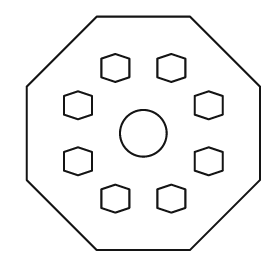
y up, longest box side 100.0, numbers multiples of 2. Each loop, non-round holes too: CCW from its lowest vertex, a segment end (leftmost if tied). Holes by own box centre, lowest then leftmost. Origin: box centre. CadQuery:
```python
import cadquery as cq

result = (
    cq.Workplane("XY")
    .moveTo(-20.0, -50.0)
    .lineTo(20.0, -50.0)
    .lineTo(50.0, -20.0)
    .lineTo(50.0, 20.0)
    .lineTo(20.0, 50.0)
    .lineTo(-20.0, 50.0)
    .lineTo(-50.0, 20.0)
    .lineTo(-50.0, -20.0)
    .close()
    .moveTo(-12.0, -34.0)
    .lineTo(-6.0, -32.0)
    .lineTo(-6.0, -24.0)
    .lineTo(-12.0, -22.0)
    .lineTo(-18.0, -24.0)
    .lineTo(-18.0, -32.0)
    .close()
    .moveTo(12.0, -34.0)
    .lineTo(18.0, -32.0)
    .lineTo(18.0, -24.0)
    .lineTo(12.0, -22.0)
    .lineTo(6.0, -24.0)
    .lineTo(6.0, -32.0)
    .close()
    .moveTo(-28.0, -18.0)
    .lineTo(-22.0, -16.0)
    .lineTo(-22.0, -8.0)
    .lineTo(-28.0, -6.0)
    .lineTo(-34.0, -8.0)
    .lineTo(-34.0, -16.0)
    .close()
    .moveTo(28.0, -18.0)
    .lineTo(34.0, -16.0)
    .lineTo(34.0, -8.0)
    .lineTo(28.0, -6.0)
    .lineTo(22.0, -8.0)
    .lineTo(22.0, -16.0)
    .close()
    .moveTo(0.0, 0.0)
    .circle(10.0)
    .moveTo(-28.0, 6.0)
    .lineTo(-22.0, 8.0)
    .lineTo(-22.0, 16.0)
    .lineTo(-28.0, 18.0)
    .lineTo(-34.0, 16.0)
    .lineTo(-34.0, 8.0)
    .close()
    .moveTo(28.0, 6.0)
    .lineTo(34.0, 8.0)
    .lineTo(34.0, 16.0)
    .lineTo(28.0, 18.0)
    .lineTo(22.0, 16.0)
    .lineTo(22.0, 8.0)
    .close()
    .moveTo(-12.0, 22.0)
    .lineTo(-6.0, 24.0)
    .lineTo(-6.0, 32.0)
    .lineTo(-12.0, 34.0)
    .lineTo(-18.0, 32.0)
    .lineTo(-18.0, 24.0)
    .close()
    .moveTo(12.0, 22.0)
    .lineTo(18.0, 24.0)
    .lineTo(18.0, 32.0)
    .lineTo(12.0, 34.0)
    .lineTo(6.0, 32.0)
    .lineTo(6.0, 24.0)
    .close()
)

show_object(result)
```